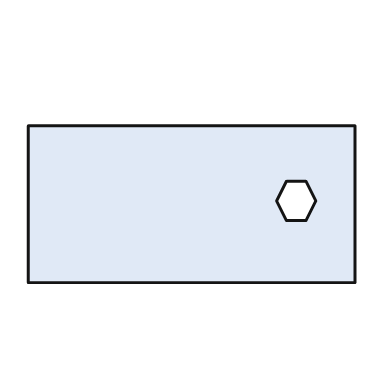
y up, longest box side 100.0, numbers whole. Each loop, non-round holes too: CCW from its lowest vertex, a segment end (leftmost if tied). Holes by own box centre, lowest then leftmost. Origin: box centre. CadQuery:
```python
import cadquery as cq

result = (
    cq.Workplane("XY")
    .moveTo(-50.0, -24.0)
    .lineTo(50.0, -24.0)
    .lineTo(50.0, 24.0)
    .lineTo(-50.0, 24.0)
    .close()
    .moveTo(29.0, -5.0)
    .lineTo(35.0, -5.0)
    .lineTo(38.0, 1.0)
    .lineTo(35.0, 7.0)
    .lineTo(29.0, 7.0)
    .lineTo(26.0, 1.0)
    .close()
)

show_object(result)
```